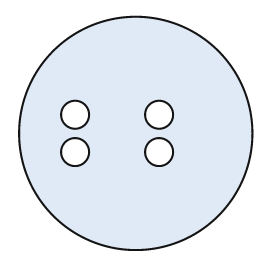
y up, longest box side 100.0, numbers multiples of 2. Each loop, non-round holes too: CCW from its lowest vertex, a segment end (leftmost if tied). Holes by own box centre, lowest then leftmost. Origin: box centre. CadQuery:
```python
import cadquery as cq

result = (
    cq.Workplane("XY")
    .moveTo(0.0, 0.0)
    .circle(50.0)
    .moveTo(-26.0, -8.0)
    .circle(6.0)
    .moveTo(10.0, -8.0)
    .circle(6.0)
    .moveTo(-26.0, 8.0)
    .circle(6.0)
    .moveTo(10.0, 8.0)
    .circle(6.0)
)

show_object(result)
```